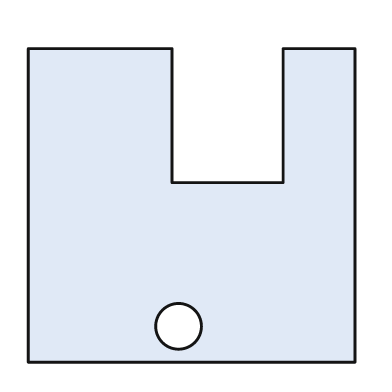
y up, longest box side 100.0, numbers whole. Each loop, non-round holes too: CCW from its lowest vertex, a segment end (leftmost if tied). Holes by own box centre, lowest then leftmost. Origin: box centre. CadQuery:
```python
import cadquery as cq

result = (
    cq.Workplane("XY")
    .moveTo(-50.0, -48.0)
    .lineTo(50.0, -48.0)
    .lineTo(50.0, 48.0)
    .lineTo(28.0, 48.0)
    .lineTo(28.0, 7.0)
    .lineTo(-6.0, 7.0)
    .lineTo(-6.0, 48.0)
    .lineTo(-50.0, 48.0)
    .close()
    .moveTo(-4.0, -37.0)
    .circle(7.0)
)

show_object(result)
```